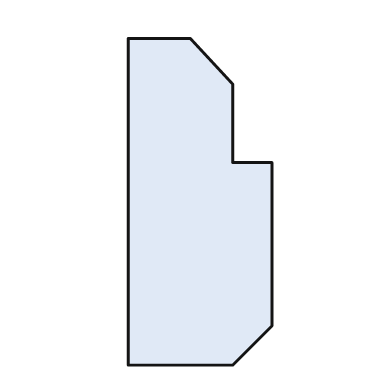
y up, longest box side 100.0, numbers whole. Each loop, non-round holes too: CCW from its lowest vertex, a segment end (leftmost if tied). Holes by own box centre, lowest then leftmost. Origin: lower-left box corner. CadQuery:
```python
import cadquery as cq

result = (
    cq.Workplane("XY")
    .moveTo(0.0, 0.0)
    .lineTo(32.0, 0.0)
    .lineTo(44.0, 12.0)
    .lineTo(44.0, 62.0)
    .lineTo(32.0, 62.0)
    .lineTo(32.0, 86.0)
    .lineTo(19.0, 100.0)
    .lineTo(0.0, 100.0)
    .close()
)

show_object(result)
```